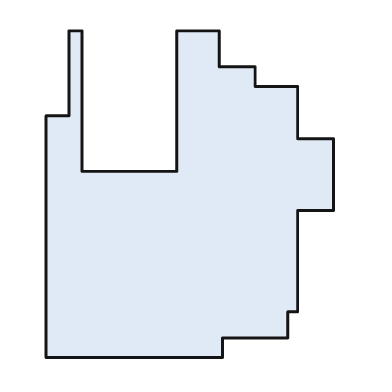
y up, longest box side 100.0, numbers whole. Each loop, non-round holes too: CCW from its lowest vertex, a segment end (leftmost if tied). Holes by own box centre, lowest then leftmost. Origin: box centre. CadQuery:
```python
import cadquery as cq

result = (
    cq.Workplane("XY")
    .moveTo(-44.0, -50.0)
    .lineTo(10.0, -50.0)
    .lineTo(10.0, -44.0)
    .lineTo(30.0, -44.0)
    .lineTo(30.0, -36.0)
    .lineTo(33.0, -36.0)
    .lineTo(33.0, -5.0)
    .lineTo(44.0, -5.0)
    .lineTo(44.0, 17.0)
    .lineTo(33.0, 17.0)
    .lineTo(33.0, 33.0)
    .lineTo(20.0, 33.0)
    .lineTo(20.0, 39.0)
    .lineTo(9.0, 39.0)
    .lineTo(9.0, 50.0)
    .lineTo(-4.0, 50.0)
    .lineTo(-4.0, 7.0)
    .lineTo(-33.0, 7.0)
    .lineTo(-33.0, 50.0)
    .lineTo(-37.0, 50.0)
    .lineTo(-37.0, 24.0)
    .lineTo(-44.0, 24.0)
    .close()
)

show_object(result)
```